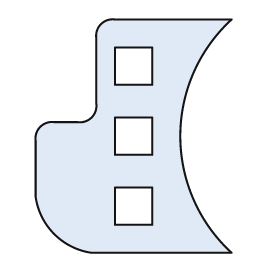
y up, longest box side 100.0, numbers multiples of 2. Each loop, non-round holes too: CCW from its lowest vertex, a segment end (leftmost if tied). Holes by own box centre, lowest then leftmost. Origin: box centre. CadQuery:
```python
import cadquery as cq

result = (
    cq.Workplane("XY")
    .moveTo(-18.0, -50.0)
    .lineTo(42.0, -50.0)
    .threePointArc((20.0, 0.0), (42.0, 50.0))
    .lineTo(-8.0, 50.0)
    .threePointArc((-14.0, 48.0), (-16.0, 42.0))
    .lineTo(-16.0, 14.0)
    .threePointArc((-18.0, 8.0), (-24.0, 6.0))
    .lineTo(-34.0, 6.0)
    .threePointArc((-40.0, 4.0), (-42.0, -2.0))
    .lineTo(-42.0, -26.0)
    .threePointArc((-34.0, -42.0), (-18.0, -50.0))
    .close()
    .moveTo(-8.0, -38.0)
    .lineTo(8.0, -38.0)
    .lineTo(8.0, -22.0)
    .lineTo(-8.0, -22.0)
    .close()
    .moveTo(-8.0, -8.0)
    .lineTo(8.0, -8.0)
    .lineTo(8.0, 8.0)
    .lineTo(-8.0, 8.0)
    .close()
    .moveTo(-8.0, 22.0)
    .lineTo(8.0, 22.0)
    .lineTo(8.0, 38.0)
    .lineTo(-8.0, 38.0)
    .close()
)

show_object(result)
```